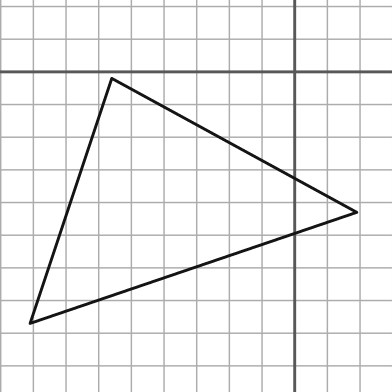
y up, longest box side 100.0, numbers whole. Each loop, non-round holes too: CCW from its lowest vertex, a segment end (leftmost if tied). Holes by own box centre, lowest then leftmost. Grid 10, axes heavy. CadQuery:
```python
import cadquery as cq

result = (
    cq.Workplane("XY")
    .moveTo(-81.0, -77.0)
    .lineTo(19.0, -43.0)
    .lineTo(-56.0, -2.0)
    .close()
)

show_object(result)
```